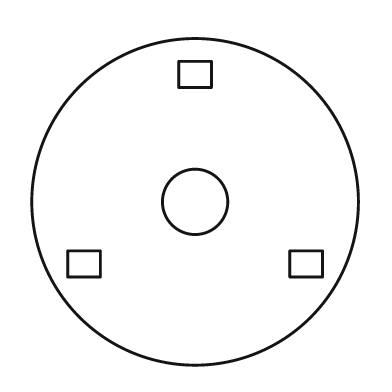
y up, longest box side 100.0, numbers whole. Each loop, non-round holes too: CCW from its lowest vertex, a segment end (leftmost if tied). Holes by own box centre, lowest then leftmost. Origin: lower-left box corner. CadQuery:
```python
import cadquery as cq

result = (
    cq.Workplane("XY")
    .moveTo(50.0, 50.0)
    .circle(50.0)
    .moveTo(11.0, 27.0)
    .lineTo(21.0, 27.0)
    .lineTo(21.0, 35.0)
    .lineTo(11.0, 35.0)
    .close()
    .moveTo(79.0, 27.0)
    .lineTo(89.0, 27.0)
    .lineTo(89.0, 35.0)
    .lineTo(79.0, 35.0)
    .close()
    .moveTo(50.0, 50.0)
    .circle(10.0)
    .moveTo(45.0, 85.0)
    .lineTo(55.0, 85.0)
    .lineTo(55.0, 93.0)
    .lineTo(45.0, 93.0)
    .close()
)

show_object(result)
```